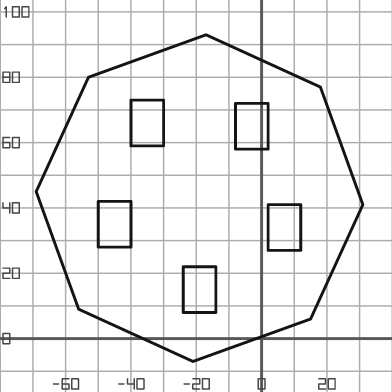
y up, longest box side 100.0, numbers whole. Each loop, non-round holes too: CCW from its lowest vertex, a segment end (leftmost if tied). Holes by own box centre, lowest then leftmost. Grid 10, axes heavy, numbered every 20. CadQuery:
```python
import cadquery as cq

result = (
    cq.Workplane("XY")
    .moveTo(-21.0, -7.0)
    .lineTo(15.0, 6.0)
    .lineTo(31.0, 41.0)
    .lineTo(18.0, 77.0)
    .lineTo(-17.0, 93.0)
    .lineTo(-53.0, 80.0)
    .lineTo(-69.0, 45.0)
    .lineTo(-56.0, 9.0)
    .close()
    .moveTo(-24.0, 8.0)
    .lineTo(-14.0, 8.0)
    .lineTo(-14.0, 22.0)
    .lineTo(-24.0, 22.0)
    .close()
    .moveTo(2.0, 27.0)
    .lineTo(12.0, 27.0)
    .lineTo(12.0, 41.0)
    .lineTo(2.0, 41.0)
    .close()
    .moveTo(-50.0, 28.0)
    .lineTo(-40.0, 28.0)
    .lineTo(-40.0, 42.0)
    .lineTo(-50.0, 42.0)
    .close()
    .moveTo(-8.0, 58.0)
    .lineTo(2.0, 58.0)
    .lineTo(2.0, 72.0)
    .lineTo(-8.0, 72.0)
    .close()
    .moveTo(-40.0, 59.0)
    .lineTo(-30.0, 59.0)
    .lineTo(-30.0, 73.0)
    .lineTo(-40.0, 73.0)
    .close()
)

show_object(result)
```